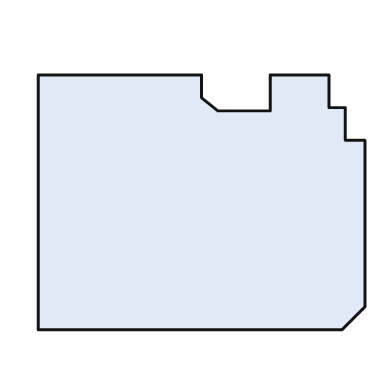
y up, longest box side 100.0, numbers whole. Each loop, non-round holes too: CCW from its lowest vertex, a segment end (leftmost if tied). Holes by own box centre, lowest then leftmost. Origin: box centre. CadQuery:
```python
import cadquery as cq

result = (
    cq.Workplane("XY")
    .moveTo(-50.0, -39.0)
    .lineTo(43.0, -39.0)
    .lineTo(50.0, -32.0)
    .lineTo(50.0, 19.0)
    .lineTo(44.0, 19.0)
    .lineTo(44.0, 29.0)
    .lineTo(39.0, 29.0)
    .lineTo(39.0, 39.0)
    .lineTo(21.0, 39.0)
    .lineTo(21.0, 28.0)
    .lineTo(5.0, 28.0)
    .lineTo(0.0, 32.0)
    .lineTo(0.0, 39.0)
    .lineTo(-50.0, 39.0)
    .close()
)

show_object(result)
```